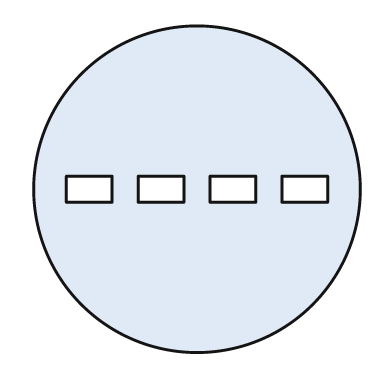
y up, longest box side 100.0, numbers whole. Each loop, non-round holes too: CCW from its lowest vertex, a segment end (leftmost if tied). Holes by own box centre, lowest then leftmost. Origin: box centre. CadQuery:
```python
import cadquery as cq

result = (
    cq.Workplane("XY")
    .moveTo(0.0, 0.0)
    .circle(50.0)
    .moveTo(-40.0, -4.0)
    .lineTo(-26.0, -4.0)
    .lineTo(-26.0, 4.0)
    .lineTo(-40.0, 4.0)
    .close()
    .moveTo(-18.0, -4.0)
    .lineTo(-4.0, -4.0)
    .lineTo(-4.0, 4.0)
    .lineTo(-18.0, 4.0)
    .close()
    .moveTo(4.0, -4.0)
    .lineTo(18.0, -4.0)
    .lineTo(18.0, 4.0)
    .lineTo(4.0, 4.0)
    .close()
    .moveTo(26.0, -4.0)
    .lineTo(40.0, -4.0)
    .lineTo(40.0, 4.0)
    .lineTo(26.0, 4.0)
    .close()
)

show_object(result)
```